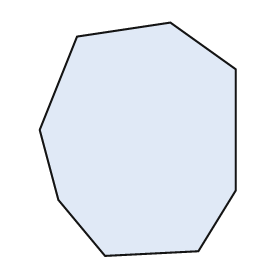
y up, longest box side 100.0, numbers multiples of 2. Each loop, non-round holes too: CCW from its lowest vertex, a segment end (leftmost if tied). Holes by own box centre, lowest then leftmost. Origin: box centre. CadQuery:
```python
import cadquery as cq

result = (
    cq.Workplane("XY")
    .moveTo(-14.0, -50.0)
    .lineTo(26.0, -48.0)
    .lineTo(42.0, -22.0)
    .lineTo(42.0, 30.0)
    .lineTo(14.0, 50.0)
    .lineTo(-26.0, 44.0)
    .lineTo(-42.0, 4.0)
    .lineTo(-34.0, -26.0)
    .close()
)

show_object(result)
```